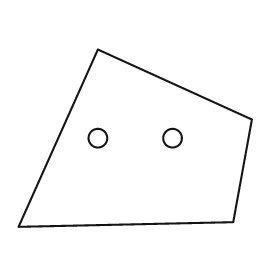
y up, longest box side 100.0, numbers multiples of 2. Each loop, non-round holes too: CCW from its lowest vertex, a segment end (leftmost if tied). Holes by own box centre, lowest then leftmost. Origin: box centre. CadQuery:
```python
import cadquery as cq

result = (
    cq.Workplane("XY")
    .moveTo(-50.0, -38.0)
    .lineTo(42.0, -36.0)
    .lineTo(50.0, 8.0)
    .lineTo(-16.0, 38.0)
    .close()
    .moveTo(-16.0, 0.0)
    .circle(4.0)
    .moveTo(16.0, 0.0)
    .circle(4.0)
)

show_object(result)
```